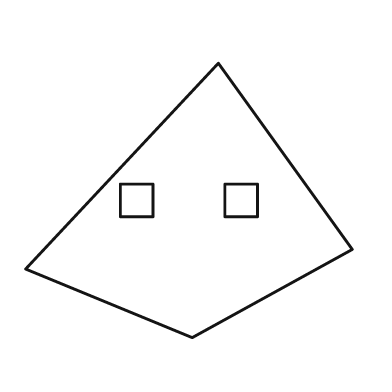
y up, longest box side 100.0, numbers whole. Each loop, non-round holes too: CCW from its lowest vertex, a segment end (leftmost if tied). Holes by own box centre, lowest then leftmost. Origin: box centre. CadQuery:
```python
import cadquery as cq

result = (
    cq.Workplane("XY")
    .moveTo(1.0, -42.0)
    .lineTo(50.0, -15.0)
    .lineTo(9.0, 42.0)
    .lineTo(-50.0, -21.0)
    .close()
    .moveTo(-21.0, -5.0)
    .lineTo(-11.0, -5.0)
    .lineTo(-11.0, 5.0)
    .lineTo(-21.0, 5.0)
    .close()
    .moveTo(11.0, -5.0)
    .lineTo(21.0, -5.0)
    .lineTo(21.0, 5.0)
    .lineTo(11.0, 5.0)
    .close()
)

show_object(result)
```